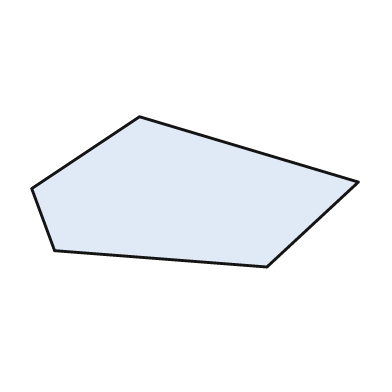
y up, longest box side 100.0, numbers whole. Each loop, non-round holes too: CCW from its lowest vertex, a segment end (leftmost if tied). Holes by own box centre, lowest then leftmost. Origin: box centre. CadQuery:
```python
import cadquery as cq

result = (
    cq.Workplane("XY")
    .moveTo(22.0, -23.0)
    .lineTo(50.0, 3.0)
    .lineTo(-17.0, 23.0)
    .lineTo(-50.0, 1.0)
    .lineTo(-43.0, -18.0)
    .close()
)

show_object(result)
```